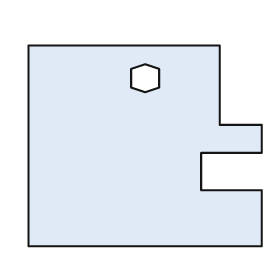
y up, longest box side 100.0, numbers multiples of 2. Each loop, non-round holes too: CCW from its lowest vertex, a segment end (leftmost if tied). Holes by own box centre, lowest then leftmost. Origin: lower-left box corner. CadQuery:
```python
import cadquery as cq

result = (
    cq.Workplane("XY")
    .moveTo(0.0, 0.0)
    .lineTo(100.0, 0.0)
    .lineTo(100.0, 24.0)
    .lineTo(74.0, 24.0)
    .lineTo(74.0, 40.0)
    .lineTo(100.0, 40.0)
    .lineTo(100.0, 52.0)
    .lineTo(82.0, 52.0)
    .lineTo(82.0, 86.0)
    .lineTo(0.0, 86.0)
    .close()
    .moveTo(50.0, 66.0)
    .lineTo(56.0, 68.0)
    .lineTo(56.0, 76.0)
    .lineTo(50.0, 78.0)
    .lineTo(44.0, 76.0)
    .lineTo(44.0, 68.0)
    .close()
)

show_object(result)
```